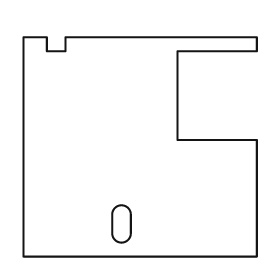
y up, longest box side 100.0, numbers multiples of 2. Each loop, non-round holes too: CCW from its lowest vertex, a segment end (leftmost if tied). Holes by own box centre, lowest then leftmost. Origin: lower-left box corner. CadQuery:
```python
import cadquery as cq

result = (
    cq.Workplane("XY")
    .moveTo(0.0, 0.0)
    .lineTo(100.0, 0.0)
    .lineTo(100.0, 50.0)
    .lineTo(66.0, 50.0)
    .lineTo(66.0, 88.0)
    .lineTo(100.0, 88.0)
    .lineTo(100.0, 94.0)
    .lineTo(18.0, 94.0)
    .lineTo(18.0, 88.0)
    .lineTo(10.0, 88.0)
    .lineTo(10.0, 94.0)
    .lineTo(0.0, 94.0)
    .close()
    .moveTo(38.0, 10.0)
    .threePointArc((42.0, 6.0), (46.0, 10.0))
    .lineTo(46.0, 18.0)
    .threePointArc((42.0, 22.0), (38.0, 18.0))
    .close()
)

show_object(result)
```